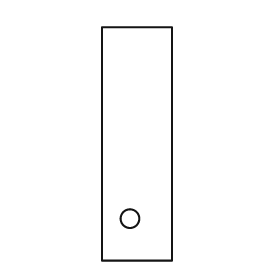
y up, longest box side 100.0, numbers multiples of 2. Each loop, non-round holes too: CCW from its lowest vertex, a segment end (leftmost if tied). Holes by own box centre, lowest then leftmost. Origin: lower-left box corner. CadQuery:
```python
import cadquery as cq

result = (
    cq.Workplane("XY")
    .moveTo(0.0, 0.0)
    .lineTo(30.0, 0.0)
    .lineTo(30.0, 100.0)
    .lineTo(0.0, 100.0)
    .close()
    .moveTo(12.0, 18.0)
    .circle(4.0)
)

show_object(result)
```